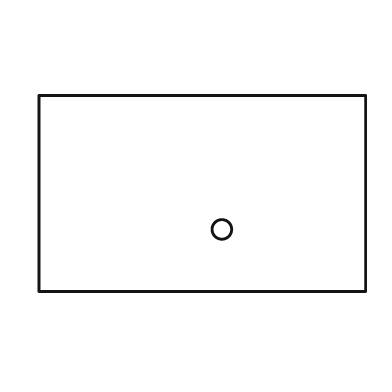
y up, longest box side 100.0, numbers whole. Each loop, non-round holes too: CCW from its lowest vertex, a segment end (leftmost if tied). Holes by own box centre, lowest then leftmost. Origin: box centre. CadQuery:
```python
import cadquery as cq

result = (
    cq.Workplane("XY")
    .moveTo(-50.0, -30.0)
    .lineTo(50.0, -30.0)
    .lineTo(50.0, 30.0)
    .lineTo(-50.0, 30.0)
    .close()
    .moveTo(6.0, -11.0)
    .circle(3.0)
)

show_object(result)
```